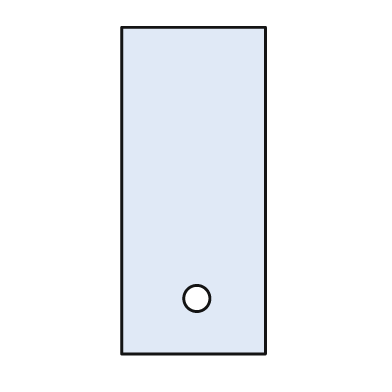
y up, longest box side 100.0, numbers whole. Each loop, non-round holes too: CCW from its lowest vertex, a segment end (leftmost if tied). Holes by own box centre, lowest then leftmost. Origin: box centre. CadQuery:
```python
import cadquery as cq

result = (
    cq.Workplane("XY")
    .moveTo(-22.0, -50.0)
    .lineTo(22.0, -50.0)
    .lineTo(22.0, 50.0)
    .lineTo(-22.0, 50.0)
    .close()
    .moveTo(1.0, -33.0)
    .circle(4.0)
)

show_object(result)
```